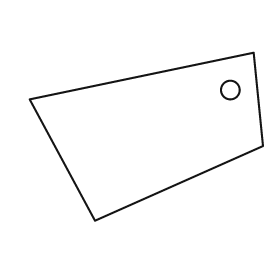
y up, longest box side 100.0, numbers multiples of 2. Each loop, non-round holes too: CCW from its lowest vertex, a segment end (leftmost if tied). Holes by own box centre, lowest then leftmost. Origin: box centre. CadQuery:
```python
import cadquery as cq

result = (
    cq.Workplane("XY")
    .moveTo(-22.0, -36.0)
    .lineTo(50.0, -4.0)
    .lineTo(46.0, 36.0)
    .lineTo(-50.0, 16.0)
    .close()
    .moveTo(36.0, 20.0)
    .circle(4.0)
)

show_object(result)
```